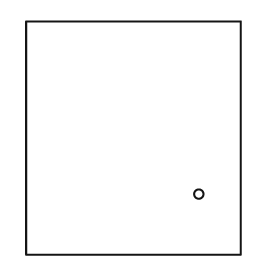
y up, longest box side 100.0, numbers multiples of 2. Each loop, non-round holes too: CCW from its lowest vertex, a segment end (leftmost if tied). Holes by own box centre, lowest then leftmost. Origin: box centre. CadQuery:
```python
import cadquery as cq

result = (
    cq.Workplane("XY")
    .moveTo(-46.0, -50.0)
    .lineTo(46.0, -50.0)
    .lineTo(46.0, 50.0)
    .lineTo(-46.0, 50.0)
    .close()
    .moveTo(28.0, -24.0)
    .circle(2.0)
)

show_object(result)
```